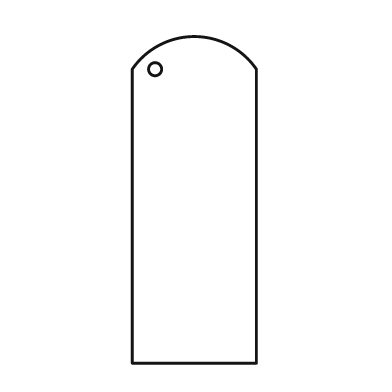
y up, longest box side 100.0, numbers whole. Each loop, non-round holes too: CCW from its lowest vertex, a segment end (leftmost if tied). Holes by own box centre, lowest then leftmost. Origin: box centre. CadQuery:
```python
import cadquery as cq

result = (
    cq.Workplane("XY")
    .moveTo(-19.0, -50.0)
    .lineTo(19.0, -50.0)
    .lineTo(19.0, 40.0)
    .threePointArc((0.0, 50.0), (-19.0, 40.0))
    .close()
    .moveTo(-12.0, 40.0)
    .circle(2.0)
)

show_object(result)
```